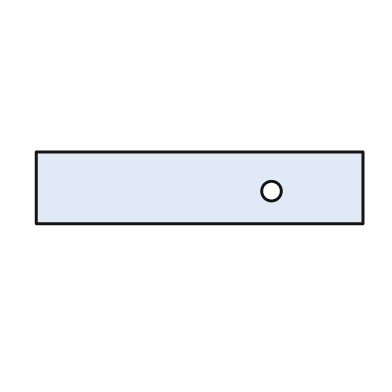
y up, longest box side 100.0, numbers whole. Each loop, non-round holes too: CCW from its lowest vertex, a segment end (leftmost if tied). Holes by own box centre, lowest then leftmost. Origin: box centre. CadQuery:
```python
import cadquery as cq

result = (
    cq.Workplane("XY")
    .moveTo(-50.0, -11.0)
    .lineTo(50.0, -11.0)
    .lineTo(50.0, 11.0)
    .lineTo(-50.0, 11.0)
    .close()
    .moveTo(22.0, -1.0)
    .circle(3.0)
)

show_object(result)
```